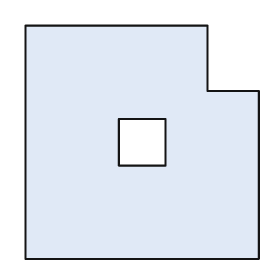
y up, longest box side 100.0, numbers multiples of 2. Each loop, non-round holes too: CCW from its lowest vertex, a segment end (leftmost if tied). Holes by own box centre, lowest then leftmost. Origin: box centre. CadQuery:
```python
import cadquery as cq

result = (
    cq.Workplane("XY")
    .moveTo(-50.0, -50.0)
    .lineTo(50.0, -50.0)
    .lineTo(50.0, 22.0)
    .lineTo(28.0, 22.0)
    .lineTo(28.0, 50.0)
    .lineTo(-50.0, 50.0)
    .close()
    .moveTo(-10.0, -10.0)
    .lineTo(10.0, -10.0)
    .lineTo(10.0, 10.0)
    .lineTo(-10.0, 10.0)
    .close()
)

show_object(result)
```